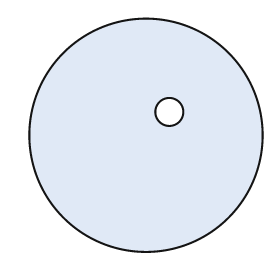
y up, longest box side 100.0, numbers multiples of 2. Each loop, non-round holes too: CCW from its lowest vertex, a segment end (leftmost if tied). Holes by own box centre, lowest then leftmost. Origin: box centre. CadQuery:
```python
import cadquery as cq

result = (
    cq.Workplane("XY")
    .moveTo(0.0, 0.0)
    .circle(50.0)
    .moveTo(10.0, 10.0)
    .circle(6.0)
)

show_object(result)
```